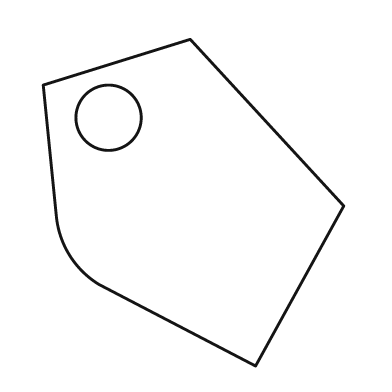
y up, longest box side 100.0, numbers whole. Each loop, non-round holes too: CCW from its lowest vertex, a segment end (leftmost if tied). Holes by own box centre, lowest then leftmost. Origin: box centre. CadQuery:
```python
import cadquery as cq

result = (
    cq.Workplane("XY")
    .moveTo(19.0, -50.0)
    .lineTo(46.0, -1.0)
    .lineTo(-1.0, 50.0)
    .lineTo(-46.0, 36.0)
    .lineTo(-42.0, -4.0)
    .threePointArc((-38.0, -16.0), (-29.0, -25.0))
    .close()
    .moveTo(-26.0, 26.0)
    .circle(10.0)
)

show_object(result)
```